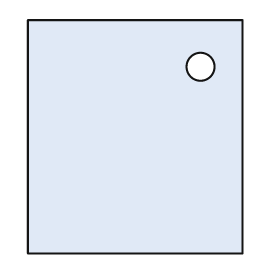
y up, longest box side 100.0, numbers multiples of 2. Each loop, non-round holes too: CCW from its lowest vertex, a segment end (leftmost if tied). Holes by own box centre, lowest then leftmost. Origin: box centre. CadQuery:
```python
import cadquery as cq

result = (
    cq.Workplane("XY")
    .moveTo(-46.0, -50.0)
    .lineTo(46.0, -50.0)
    .lineTo(46.0, 50.0)
    .lineTo(-46.0, 50.0)
    .close()
    .moveTo(28.0, 30.0)
    .circle(6.0)
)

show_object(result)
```